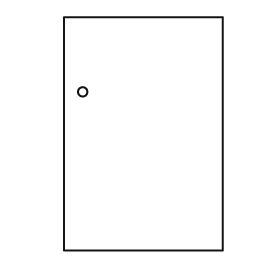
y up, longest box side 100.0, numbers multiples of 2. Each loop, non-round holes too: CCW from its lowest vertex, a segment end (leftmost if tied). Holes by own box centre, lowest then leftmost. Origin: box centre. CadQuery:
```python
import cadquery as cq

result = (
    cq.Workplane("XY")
    .moveTo(-34.0, -50.0)
    .lineTo(34.0, -50.0)
    .lineTo(34.0, 50.0)
    .lineTo(-34.0, 50.0)
    .close()
    .moveTo(-26.0, 18.0)
    .circle(2.0)
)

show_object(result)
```